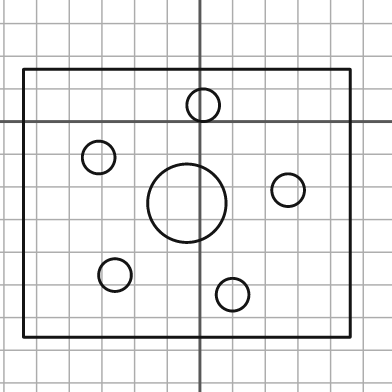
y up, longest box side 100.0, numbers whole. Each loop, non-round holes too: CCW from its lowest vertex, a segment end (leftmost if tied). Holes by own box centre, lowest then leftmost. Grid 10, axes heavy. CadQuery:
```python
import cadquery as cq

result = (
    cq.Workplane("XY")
    .moveTo(-54.0, -66.0)
    .lineTo(46.0, -66.0)
    .lineTo(46.0, 16.0)
    .lineTo(-54.0, 16.0)
    .close()
    .moveTo(10.0, -53.0)
    .circle(5.0)
    .moveTo(-26.0, -47.0)
    .circle(5.0)
    .moveTo(-4.0, -25.0)
    .circle(12.0)
    .moveTo(27.0, -21.0)
    .circle(5.0)
    .moveTo(-31.0, -11.0)
    .circle(5.0)
    .moveTo(1.0, 5.0)
    .circle(5.0)
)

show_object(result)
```